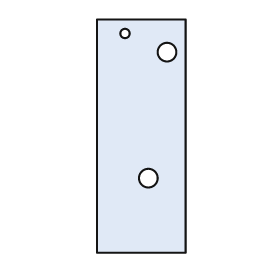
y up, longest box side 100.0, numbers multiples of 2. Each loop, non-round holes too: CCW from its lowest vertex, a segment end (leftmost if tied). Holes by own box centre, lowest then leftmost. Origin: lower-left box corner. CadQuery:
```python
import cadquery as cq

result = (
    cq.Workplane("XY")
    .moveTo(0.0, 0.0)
    .lineTo(38.0, 0.0)
    .lineTo(38.0, 100.0)
    .lineTo(0.0, 100.0)
    .close()
    .moveTo(22.0, 32.0)
    .circle(4.0)
    .moveTo(30.0, 86.0)
    .circle(4.0)
    .moveTo(12.0, 94.0)
    .circle(2.0)
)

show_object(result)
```